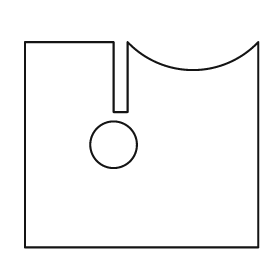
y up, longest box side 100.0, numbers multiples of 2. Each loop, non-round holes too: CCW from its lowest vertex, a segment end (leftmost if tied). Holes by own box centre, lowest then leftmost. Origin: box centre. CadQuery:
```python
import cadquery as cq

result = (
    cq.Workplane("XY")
    .moveTo(-50.0, -44.0)
    .lineTo(50.0, -44.0)
    .lineTo(50.0, 44.0)
    .threePointArc((22.0, 32.0), (-6.0, 44.0))
    .lineTo(-6.0, 14.0)
    .lineTo(-12.0, 14.0)
    .lineTo(-12.0, 44.0)
    .lineTo(-50.0, 44.0)
    .close()
    .moveTo(-12.0, 0.0)
    .circle(10.0)
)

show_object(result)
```